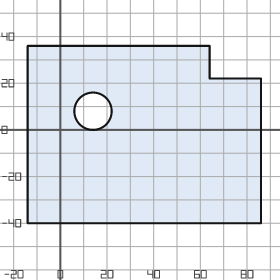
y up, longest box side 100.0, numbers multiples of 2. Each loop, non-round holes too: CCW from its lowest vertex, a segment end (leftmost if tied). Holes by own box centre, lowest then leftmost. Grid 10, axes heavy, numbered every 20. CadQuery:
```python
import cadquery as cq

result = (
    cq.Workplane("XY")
    .moveTo(-14.0, -40.0)
    .lineTo(86.0, -40.0)
    .lineTo(86.0, 22.0)
    .lineTo(64.0, 22.0)
    .lineTo(64.0, 36.0)
    .lineTo(-14.0, 36.0)
    .close()
    .moveTo(14.0, 8.0)
    .circle(8.0)
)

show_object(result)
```